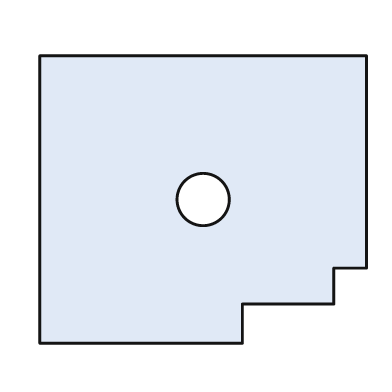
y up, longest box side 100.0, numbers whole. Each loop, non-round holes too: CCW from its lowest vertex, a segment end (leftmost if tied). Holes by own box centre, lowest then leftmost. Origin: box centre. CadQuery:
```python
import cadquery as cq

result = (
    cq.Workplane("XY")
    .moveTo(-50.0, -44.0)
    .lineTo(12.0, -44.0)
    .lineTo(12.0, -32.0)
    .lineTo(40.0, -32.0)
    .lineTo(40.0, -21.0)
    .lineTo(50.0, -21.0)
    .lineTo(50.0, 44.0)
    .lineTo(-50.0, 44.0)
    .close()
    .moveTo(0.0, 0.0)
    .circle(8.0)
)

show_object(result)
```